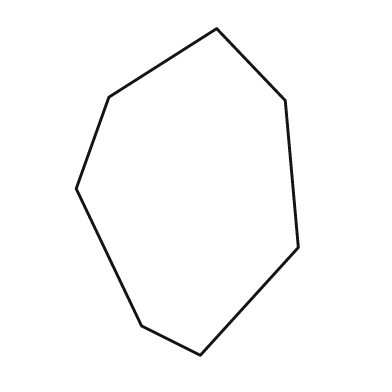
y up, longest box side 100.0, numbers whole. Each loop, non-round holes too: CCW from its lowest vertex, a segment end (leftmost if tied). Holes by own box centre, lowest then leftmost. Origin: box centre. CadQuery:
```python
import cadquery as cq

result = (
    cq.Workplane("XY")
    .moveTo(4.0, -50.0)
    .lineTo(34.0, -17.0)
    .lineTo(30.0, 28.0)
    .lineTo(9.0, 50.0)
    .lineTo(-24.0, 29.0)
    .lineTo(-34.0, 1.0)
    .lineTo(-14.0, -41.0)
    .close()
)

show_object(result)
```